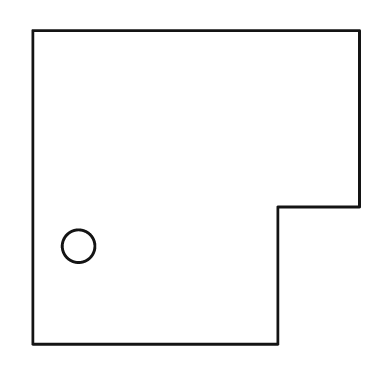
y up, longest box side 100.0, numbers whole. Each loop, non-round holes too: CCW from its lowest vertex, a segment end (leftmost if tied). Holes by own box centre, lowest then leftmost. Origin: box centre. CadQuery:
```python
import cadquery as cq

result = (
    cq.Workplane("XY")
    .moveTo(-50.0, -48.0)
    .lineTo(25.0, -48.0)
    .lineTo(25.0, -6.0)
    .lineTo(50.0, -6.0)
    .lineTo(50.0, 48.0)
    .lineTo(-50.0, 48.0)
    .close()
    .moveTo(-36.0, -18.0)
    .circle(5.0)
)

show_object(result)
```